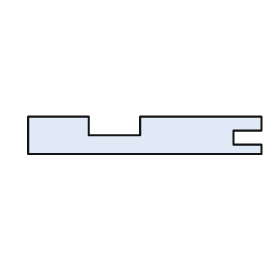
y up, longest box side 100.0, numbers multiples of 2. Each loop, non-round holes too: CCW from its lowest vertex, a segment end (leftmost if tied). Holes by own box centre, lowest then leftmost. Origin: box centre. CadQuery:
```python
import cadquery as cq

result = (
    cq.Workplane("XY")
    .moveTo(-50.0, -8.0)
    .lineTo(50.0, -8.0)
    .lineTo(50.0, -4.0)
    .lineTo(38.0, -4.0)
    .lineTo(38.0, 2.0)
    .lineTo(50.0, 2.0)
    .lineTo(50.0, 8.0)
    .lineTo(-2.0, 8.0)
    .lineTo(-2.0, 0.0)
    .lineTo(-24.0, 0.0)
    .lineTo(-24.0, 8.0)
    .lineTo(-50.0, 8.0)
    .close()
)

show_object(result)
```